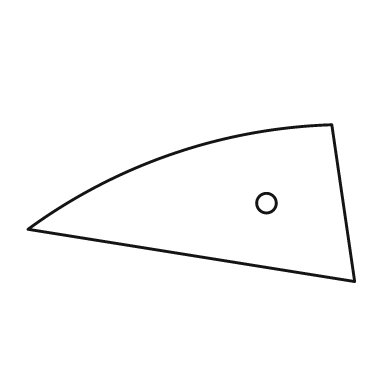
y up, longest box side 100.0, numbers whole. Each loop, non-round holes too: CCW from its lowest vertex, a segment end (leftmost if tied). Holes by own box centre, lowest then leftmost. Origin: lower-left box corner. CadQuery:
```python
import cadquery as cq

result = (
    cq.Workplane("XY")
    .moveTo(100.0, 0.0)
    .lineTo(93.0, 48.0)
    .threePointArc((44.0, 39.0), (0.0, 16.0))
    .close()
    .moveTo(73.0, 24.0)
    .circle(3.0)
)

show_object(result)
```